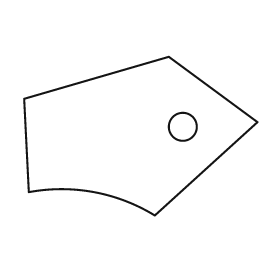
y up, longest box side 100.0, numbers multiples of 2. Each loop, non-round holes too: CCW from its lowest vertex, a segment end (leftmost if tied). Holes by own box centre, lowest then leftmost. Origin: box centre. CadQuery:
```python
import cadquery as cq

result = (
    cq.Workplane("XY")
    .moveTo(6.0, -34.0)
    .lineTo(50.0, 6.0)
    .lineTo(12.0, 34.0)
    .lineTo(-50.0, 16.0)
    .lineTo(-48.0, -24.0)
    .threePointArc((-20.0, -24.0), (6.0, -34.0))
    .close()
    .moveTo(18.0, 4.0)
    .circle(6.0)
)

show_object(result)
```